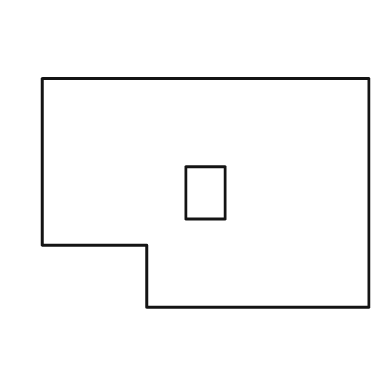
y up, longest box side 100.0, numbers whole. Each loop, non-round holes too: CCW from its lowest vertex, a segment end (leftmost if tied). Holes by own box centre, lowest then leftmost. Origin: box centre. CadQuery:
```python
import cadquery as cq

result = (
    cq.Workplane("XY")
    .moveTo(-18.0, -35.0)
    .lineTo(50.0, -35.0)
    .lineTo(50.0, 35.0)
    .lineTo(-50.0, 35.0)
    .lineTo(-50.0, -16.0)
    .lineTo(-18.0, -16.0)
    .close()
    .moveTo(-6.0, -8.0)
    .lineTo(6.0, -8.0)
    .lineTo(6.0, 8.0)
    .lineTo(-6.0, 8.0)
    .close()
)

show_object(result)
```